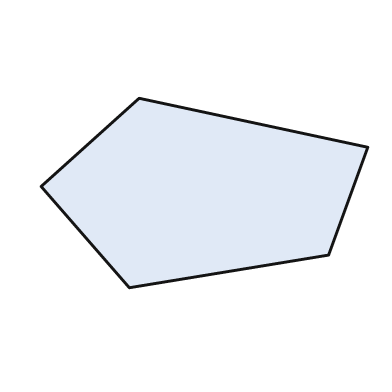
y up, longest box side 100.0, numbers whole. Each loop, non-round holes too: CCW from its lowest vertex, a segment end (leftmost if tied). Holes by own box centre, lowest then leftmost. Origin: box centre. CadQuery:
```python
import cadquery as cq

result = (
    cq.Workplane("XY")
    .moveTo(-23.0, -29.0)
    .lineTo(38.0, -19.0)
    .lineTo(50.0, 14.0)
    .lineTo(-20.0, 29.0)
    .lineTo(-50.0, 2.0)
    .close()
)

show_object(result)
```